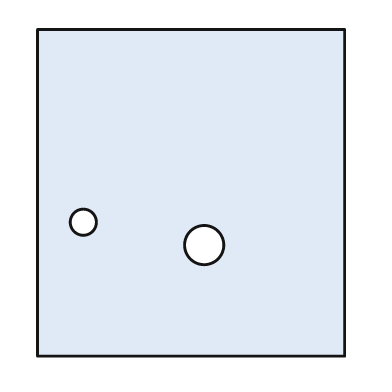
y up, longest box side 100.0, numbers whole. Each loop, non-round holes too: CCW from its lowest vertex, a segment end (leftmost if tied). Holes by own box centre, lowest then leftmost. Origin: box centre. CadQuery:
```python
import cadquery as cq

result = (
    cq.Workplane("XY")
    .moveTo(-47.0, -50.0)
    .lineTo(47.0, -50.0)
    .lineTo(47.0, 50.0)
    .lineTo(-47.0, 50.0)
    .close()
    .moveTo(4.0, -16.0)
    .circle(6.0)
    .moveTo(-33.0, -9.0)
    .circle(4.0)
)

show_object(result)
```